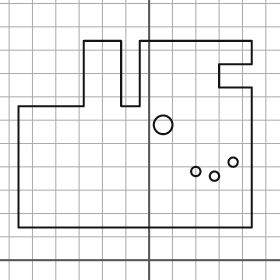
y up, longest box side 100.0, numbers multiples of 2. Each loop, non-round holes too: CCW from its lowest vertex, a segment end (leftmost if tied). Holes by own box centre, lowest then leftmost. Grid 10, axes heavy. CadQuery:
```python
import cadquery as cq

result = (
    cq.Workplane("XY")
    .moveTo(-56.0, 14.0)
    .lineTo(44.0, 14.0)
    .lineTo(44.0, 74.0)
    .lineTo(30.0, 74.0)
    .lineTo(30.0, 84.0)
    .lineTo(44.0, 84.0)
    .lineTo(44.0, 94.0)
    .lineTo(-4.0, 94.0)
    .lineTo(-4.0, 66.0)
    .lineTo(-12.0, 66.0)
    .lineTo(-12.0, 94.0)
    .lineTo(-28.0, 94.0)
    .lineTo(-28.0, 66.0)
    .lineTo(-56.0, 66.0)
    .close()
    .moveTo(28.0, 36.0)
    .circle(2.0)
    .moveTo(20.0, 38.0)
    .circle(2.0)
    .moveTo(36.0, 42.0)
    .circle(2.0)
    .moveTo(6.0, 58.0)
    .circle(4.0)
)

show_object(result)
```